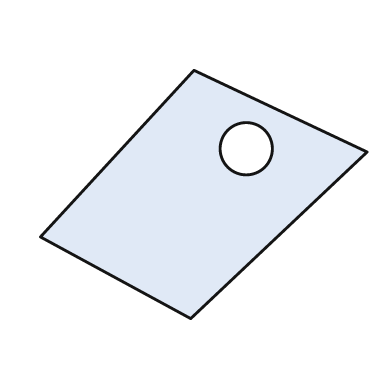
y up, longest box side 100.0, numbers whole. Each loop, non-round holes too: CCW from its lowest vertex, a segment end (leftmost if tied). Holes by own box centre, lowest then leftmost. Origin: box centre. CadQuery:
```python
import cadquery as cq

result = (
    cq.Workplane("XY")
    .moveTo(-4.0, -38.0)
    .lineTo(50.0, 13.0)
    .lineTo(-3.0, 38.0)
    .lineTo(-50.0, -13.0)
    .close()
    .moveTo(13.0, 14.0)
    .circle(8.0)
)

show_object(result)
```